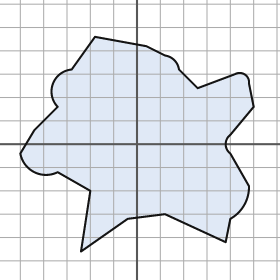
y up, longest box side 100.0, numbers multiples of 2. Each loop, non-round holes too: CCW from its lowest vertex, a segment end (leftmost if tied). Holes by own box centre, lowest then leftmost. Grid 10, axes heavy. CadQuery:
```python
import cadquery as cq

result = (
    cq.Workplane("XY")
    .moveTo(-24.0, -46.0)
    .lineTo(-4.0, -32.0)
    .lineTo(12.0, -30.0)
    .lineTo(38.0, -42.0)
    .lineTo(40.0, -32.0)
    .threePointArc((46.0, -26.0), (48.0, -18.0))
    .lineTo(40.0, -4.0)
    .threePointArc((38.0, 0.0), (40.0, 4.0))
    .lineTo(50.0, 16.0)
    .lineTo(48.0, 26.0)
    .threePointArc((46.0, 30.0), (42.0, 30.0))
    .lineTo(26.0, 24.0)
    .lineTo(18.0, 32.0)
    .threePointArc((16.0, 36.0), (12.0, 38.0))
    .lineTo(4.0, 42.0)
    .lineTo(-18.0, 46.0)
    .lineTo(-28.0, 32.0)
    .threePointArc((-36.0, 26.0), (-34.0, 16.0))
    .lineTo(-44.0, 6.0)
    .lineTo(-50.0, -4.0)
    .threePointArc((-44.0, -12.0), (-34.0, -12.0))
    .lineTo(-20.0, -20.0)
    .close()
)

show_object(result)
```